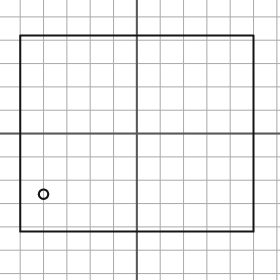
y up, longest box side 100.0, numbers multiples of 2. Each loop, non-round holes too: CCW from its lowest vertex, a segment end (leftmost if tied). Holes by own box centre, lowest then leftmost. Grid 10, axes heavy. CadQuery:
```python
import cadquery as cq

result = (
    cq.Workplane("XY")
    .moveTo(-50.0, -42.0)
    .lineTo(50.0, -42.0)
    .lineTo(50.0, 42.0)
    .lineTo(-50.0, 42.0)
    .close()
    .moveTo(-40.0, -26.0)
    .circle(2.0)
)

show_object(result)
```